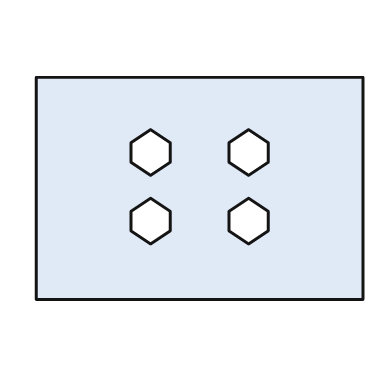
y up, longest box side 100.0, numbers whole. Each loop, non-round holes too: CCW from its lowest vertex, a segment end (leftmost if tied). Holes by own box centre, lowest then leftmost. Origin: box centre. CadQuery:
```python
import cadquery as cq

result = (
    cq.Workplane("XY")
    .moveTo(-50.0, -34.0)
    .lineTo(50.0, -34.0)
    .lineTo(50.0, 34.0)
    .lineTo(-50.0, 34.0)
    .close()
    .moveTo(-15.0, -17.0)
    .lineTo(-9.0, -13.0)
    .lineTo(-9.0, -7.0)
    .lineTo(-15.0, -3.0)
    .lineTo(-21.0, -7.0)
    .lineTo(-21.0, -13.0)
    .close()
    .moveTo(15.0, -17.0)
    .lineTo(21.0, -13.0)
    .lineTo(21.0, -7.0)
    .lineTo(15.0, -3.0)
    .lineTo(9.0, -7.0)
    .lineTo(9.0, -13.0)
    .close()
    .moveTo(-15.0, 4.0)
    .lineTo(-9.0, 8.0)
    .lineTo(-9.0, 14.0)
    .lineTo(-15.0, 18.0)
    .lineTo(-21.0, 14.0)
    .lineTo(-21.0, 8.0)
    .close()
    .moveTo(15.0, 4.0)
    .lineTo(21.0, 8.0)
    .lineTo(21.0, 14.0)
    .lineTo(15.0, 18.0)
    .lineTo(9.0, 14.0)
    .lineTo(9.0, 8.0)
    .close()
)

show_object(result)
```